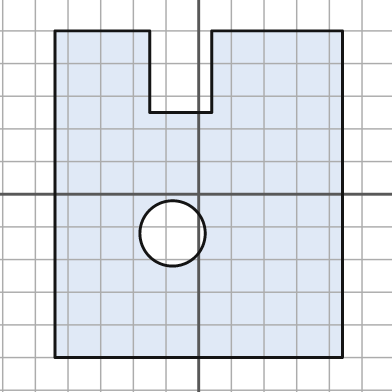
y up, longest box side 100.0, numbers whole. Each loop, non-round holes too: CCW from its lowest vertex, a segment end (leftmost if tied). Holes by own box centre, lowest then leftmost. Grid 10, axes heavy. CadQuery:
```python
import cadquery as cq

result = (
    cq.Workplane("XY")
    .moveTo(-44.0, -50.0)
    .lineTo(44.0, -50.0)
    .lineTo(44.0, 50.0)
    .lineTo(4.0, 50.0)
    .lineTo(4.0, 25.0)
    .lineTo(-15.0, 25.0)
    .lineTo(-15.0, 50.0)
    .lineTo(-44.0, 50.0)
    .close()
    .moveTo(-8.0, -12.0)
    .circle(10.0)
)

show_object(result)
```